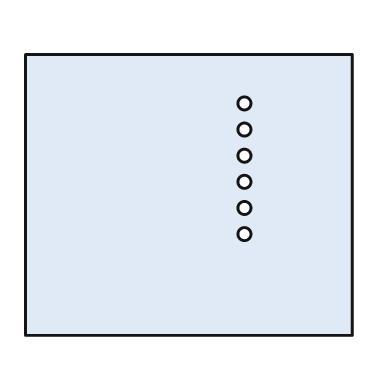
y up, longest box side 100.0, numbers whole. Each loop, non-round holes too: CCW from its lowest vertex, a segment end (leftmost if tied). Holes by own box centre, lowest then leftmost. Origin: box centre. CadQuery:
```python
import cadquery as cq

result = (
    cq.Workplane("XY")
    .moveTo(-50.0, -43.0)
    .lineTo(50.0, -43.0)
    .lineTo(50.0, 43.0)
    .lineTo(-50.0, 43.0)
    .close()
    .moveTo(17.0, -12.0)
    .circle(2.0)
    .moveTo(17.0, -4.0)
    .circle(2.0)
    .moveTo(17.0, 4.0)
    .circle(2.0)
    .moveTo(17.0, 12.0)
    .circle(2.0)
    .moveTo(17.0, 20.0)
    .circle(2.0)
    .moveTo(17.0, 28.0)
    .circle(2.0)
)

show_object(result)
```